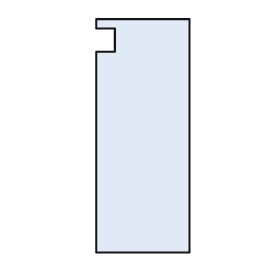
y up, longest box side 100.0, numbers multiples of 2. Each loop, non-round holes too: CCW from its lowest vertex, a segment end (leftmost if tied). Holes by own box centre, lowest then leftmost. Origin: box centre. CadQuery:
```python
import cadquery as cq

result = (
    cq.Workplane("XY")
    .moveTo(-20.0, -50.0)
    .lineTo(20.0, -50.0)
    .lineTo(20.0, 50.0)
    .lineTo(-20.0, 50.0)
    .lineTo(-20.0, 46.0)
    .lineTo(-12.0, 46.0)
    .lineTo(-12.0, 36.0)
    .lineTo(-20.0, 36.0)
    .close()
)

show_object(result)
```